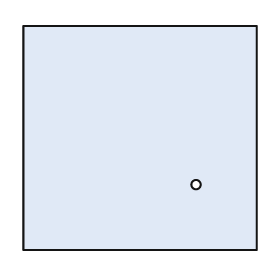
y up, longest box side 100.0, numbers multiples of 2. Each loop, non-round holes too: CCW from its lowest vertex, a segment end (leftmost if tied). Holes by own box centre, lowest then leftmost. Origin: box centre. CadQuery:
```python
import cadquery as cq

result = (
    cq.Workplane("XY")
    .moveTo(-50.0, -48.0)
    .lineTo(50.0, -48.0)
    .lineTo(50.0, 48.0)
    .lineTo(-50.0, 48.0)
    .close()
    .moveTo(24.0, -20.0)
    .circle(2.0)
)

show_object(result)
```